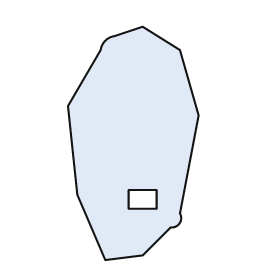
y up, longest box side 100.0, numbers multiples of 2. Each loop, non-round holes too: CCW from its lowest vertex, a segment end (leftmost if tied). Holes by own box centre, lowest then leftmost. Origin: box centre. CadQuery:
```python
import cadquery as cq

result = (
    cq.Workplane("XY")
    .moveTo(-12.0, -50.0)
    .lineTo(4.0, -48.0)
    .lineTo(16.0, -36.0)
    .threePointArc((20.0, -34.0), (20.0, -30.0))
    .lineTo(28.0, 12.0)
    .lineTo(20.0, 40.0)
    .lineTo(4.0, 50.0)
    .lineTo(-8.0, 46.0)
    .threePointArc((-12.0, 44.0), (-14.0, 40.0))
    .lineTo(-28.0, 16.0)
    .lineTo(-24.0, -22.0)
    .close()
    .moveTo(-2.0, -28.0)
    .lineTo(10.0, -28.0)
    .lineTo(10.0, -20.0)
    .lineTo(-2.0, -20.0)
    .close()
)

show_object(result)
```